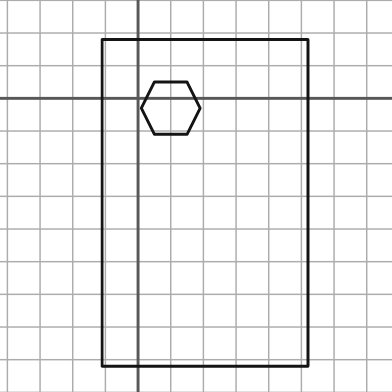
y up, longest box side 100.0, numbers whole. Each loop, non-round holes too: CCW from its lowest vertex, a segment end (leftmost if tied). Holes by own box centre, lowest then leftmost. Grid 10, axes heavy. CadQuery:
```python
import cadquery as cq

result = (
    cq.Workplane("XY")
    .moveTo(-11.0, -82.0)
    .lineTo(52.0, -82.0)
    .lineTo(52.0, 18.0)
    .lineTo(-11.0, 18.0)
    .close()
    .moveTo(5.0, -11.0)
    .lineTo(15.0, -11.0)
    .lineTo(19.0, -3.0)
    .lineTo(15.0, 5.0)
    .lineTo(5.0, 5.0)
    .lineTo(1.0, -3.0)
    .close()
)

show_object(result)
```